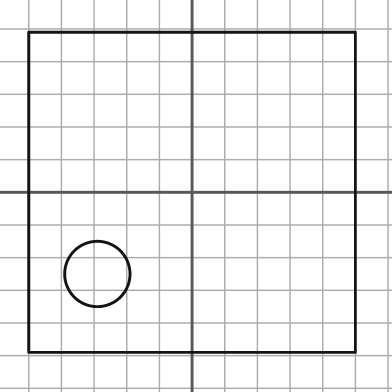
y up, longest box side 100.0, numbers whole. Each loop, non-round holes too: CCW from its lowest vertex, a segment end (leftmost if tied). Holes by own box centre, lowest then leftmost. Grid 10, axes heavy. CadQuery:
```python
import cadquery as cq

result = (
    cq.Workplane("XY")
    .moveTo(-50.0, -49.0)
    .lineTo(50.0, -49.0)
    .lineTo(50.0, 49.0)
    .lineTo(-50.0, 49.0)
    .close()
    .moveTo(-29.0, -25.0)
    .circle(10.0)
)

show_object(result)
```